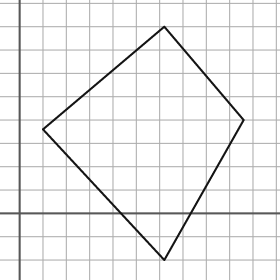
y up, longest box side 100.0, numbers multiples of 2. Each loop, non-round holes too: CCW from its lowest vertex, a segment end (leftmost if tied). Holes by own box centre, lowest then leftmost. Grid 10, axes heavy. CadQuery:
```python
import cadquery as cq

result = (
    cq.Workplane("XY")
    .moveTo(62.0, -20.0)
    .lineTo(96.0, 40.0)
    .lineTo(62.0, 80.0)
    .lineTo(10.0, 36.0)
    .close()
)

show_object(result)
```